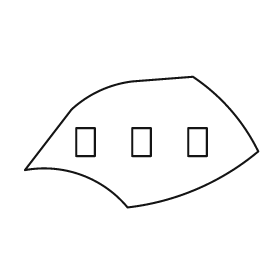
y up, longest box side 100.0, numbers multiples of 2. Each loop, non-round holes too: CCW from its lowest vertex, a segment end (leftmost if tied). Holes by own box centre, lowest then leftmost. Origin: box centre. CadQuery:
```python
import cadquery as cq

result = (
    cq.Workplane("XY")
    .moveTo(-6.0, -28.0)
    .threePointArc((24.0, -20.0), (50.0, -4.0))
    .threePointArc((38.0, 14.0), (22.0, 28.0))
    .lineTo(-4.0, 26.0)
    .threePointArc((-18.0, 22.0), (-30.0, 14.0))
    .lineTo(-50.0, -12.0)
    .threePointArc((-26.0, -14.0), (-6.0, -28.0))
    .close()
    .moveTo(-28.0, -6.0)
    .lineTo(-20.0, -6.0)
    .lineTo(-20.0, 6.0)
    .lineTo(-28.0, 6.0)
    .close()
    .moveTo(-4.0, -6.0)
    .lineTo(4.0, -6.0)
    .lineTo(4.0, 6.0)
    .lineTo(-4.0, 6.0)
    .close()
    .moveTo(20.0, -6.0)
    .lineTo(28.0, -6.0)
    .lineTo(28.0, 6.0)
    .lineTo(20.0, 6.0)
    .close()
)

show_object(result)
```